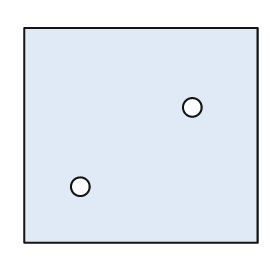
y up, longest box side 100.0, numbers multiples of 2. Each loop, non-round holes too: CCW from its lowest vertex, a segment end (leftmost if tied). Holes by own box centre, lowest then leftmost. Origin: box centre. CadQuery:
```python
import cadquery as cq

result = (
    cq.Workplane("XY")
    .moveTo(-50.0, -46.0)
    .lineTo(50.0, -46.0)
    .lineTo(50.0, 46.0)
    .lineTo(-50.0, 46.0)
    .close()
    .moveTo(-26.0, -22.0)
    .circle(4.0)
    .moveTo(22.0, 12.0)
    .circle(4.0)
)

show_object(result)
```